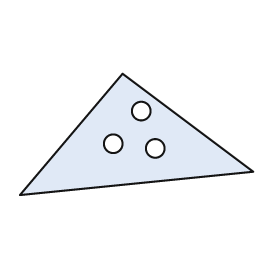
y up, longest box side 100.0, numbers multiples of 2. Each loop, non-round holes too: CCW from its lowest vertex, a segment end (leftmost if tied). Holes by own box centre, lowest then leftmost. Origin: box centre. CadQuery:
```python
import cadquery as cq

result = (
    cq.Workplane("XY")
    .moveTo(-50.0, -26.0)
    .lineTo(50.0, -16.0)
    .lineTo(-6.0, 26.0)
    .close()
    .moveTo(8.0, -6.0)
    .circle(4.0)
    .moveTo(-10.0, -4.0)
    .circle(4.0)
    .moveTo(2.0, 10.0)
    .circle(4.0)
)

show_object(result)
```